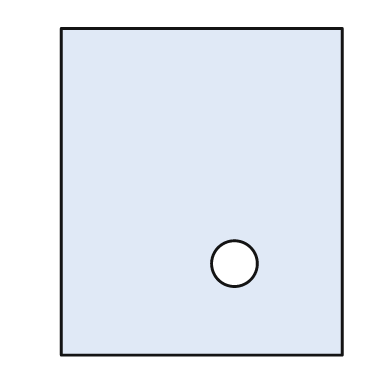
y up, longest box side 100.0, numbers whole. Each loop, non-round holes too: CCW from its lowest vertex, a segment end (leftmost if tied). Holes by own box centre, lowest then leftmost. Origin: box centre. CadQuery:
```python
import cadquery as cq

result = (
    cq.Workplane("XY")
    .moveTo(-43.0, -50.0)
    .lineTo(43.0, -50.0)
    .lineTo(43.0, 50.0)
    .lineTo(-43.0, 50.0)
    .close()
    .moveTo(10.0, -22.0)
    .circle(7.0)
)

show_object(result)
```